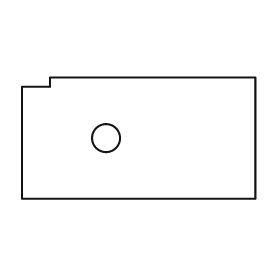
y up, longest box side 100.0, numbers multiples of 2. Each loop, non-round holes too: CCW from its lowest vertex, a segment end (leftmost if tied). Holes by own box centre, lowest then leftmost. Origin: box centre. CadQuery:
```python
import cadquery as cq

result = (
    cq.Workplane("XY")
    .moveTo(-50.0, -26.0)
    .lineTo(50.0, -26.0)
    .lineTo(50.0, 26.0)
    .lineTo(-38.0, 26.0)
    .lineTo(-38.0, 22.0)
    .lineTo(-50.0, 22.0)
    .close()
    .moveTo(-14.0, 0.0)
    .circle(6.0)
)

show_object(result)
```